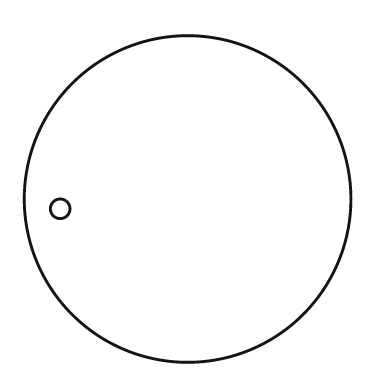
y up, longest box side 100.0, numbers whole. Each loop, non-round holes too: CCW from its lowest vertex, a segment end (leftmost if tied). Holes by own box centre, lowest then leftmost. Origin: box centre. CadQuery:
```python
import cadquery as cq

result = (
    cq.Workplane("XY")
    .moveTo(0.0, 0.0)
    .circle(50.0)
    .moveTo(-39.0, -3.0)
    .circle(3.0)
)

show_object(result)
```